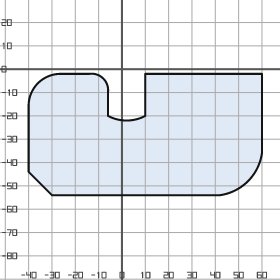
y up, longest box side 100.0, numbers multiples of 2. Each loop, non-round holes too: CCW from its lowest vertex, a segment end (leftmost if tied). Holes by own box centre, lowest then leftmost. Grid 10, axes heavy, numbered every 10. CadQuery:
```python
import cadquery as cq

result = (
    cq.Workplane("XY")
    .moveTo(-30.0, -54.0)
    .lineTo(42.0, -54.0)
    .threePointArc((54.0, -48.0), (60.0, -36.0))
    .lineTo(60.0, -2.0)
    .lineTo(10.0, -2.0)
    .lineTo(10.0, -20.0)
    .threePointArc((2.0, -22.0), (-6.0, -20.0))
    .lineTo(-6.0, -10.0)
    .threePointArc((-8.0, -4.0), (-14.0, -2.0))
    .lineTo(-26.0, -2.0)
    .threePointArc((-36.0, -6.0), (-40.0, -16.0))
    .lineTo(-40.0, -44.0)
    .close()
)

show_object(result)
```